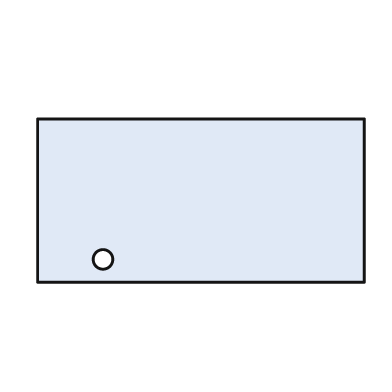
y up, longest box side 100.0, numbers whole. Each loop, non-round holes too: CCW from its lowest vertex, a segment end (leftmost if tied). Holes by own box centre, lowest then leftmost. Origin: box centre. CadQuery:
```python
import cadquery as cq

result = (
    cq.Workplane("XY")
    .moveTo(-50.0, -25.0)
    .lineTo(50.0, -25.0)
    .lineTo(50.0, 25.0)
    .lineTo(-50.0, 25.0)
    .close()
    .moveTo(-30.0, -18.0)
    .circle(3.0)
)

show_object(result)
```